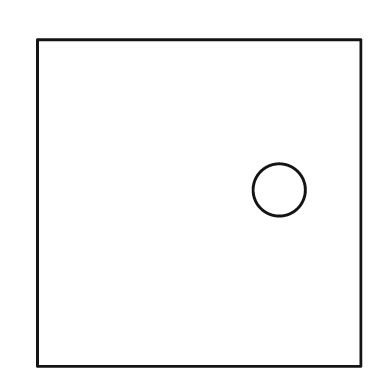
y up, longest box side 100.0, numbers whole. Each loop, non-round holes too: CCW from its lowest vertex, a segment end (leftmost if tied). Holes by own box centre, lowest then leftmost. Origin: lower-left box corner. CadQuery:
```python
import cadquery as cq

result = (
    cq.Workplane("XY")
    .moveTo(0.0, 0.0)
    .lineTo(99.0, 0.0)
    .lineTo(99.0, 100.0)
    .lineTo(0.0, 100.0)
    .close()
    .moveTo(74.0, 54.0)
    .circle(8.0)
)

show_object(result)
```